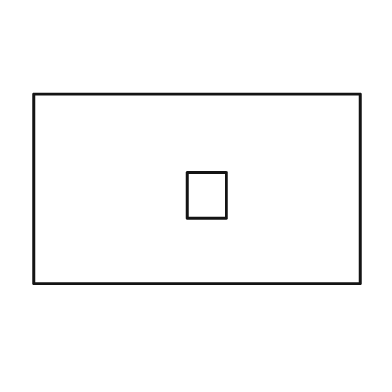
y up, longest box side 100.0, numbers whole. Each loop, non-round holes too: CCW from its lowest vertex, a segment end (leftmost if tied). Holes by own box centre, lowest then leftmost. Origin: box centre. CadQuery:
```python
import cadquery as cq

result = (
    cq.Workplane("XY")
    .moveTo(-50.0, -29.0)
    .lineTo(50.0, -29.0)
    .lineTo(50.0, 29.0)
    .lineTo(-50.0, 29.0)
    .close()
    .moveTo(-3.0, -9.0)
    .lineTo(9.0, -9.0)
    .lineTo(9.0, 5.0)
    .lineTo(-3.0, 5.0)
    .close()
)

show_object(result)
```